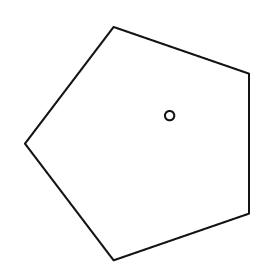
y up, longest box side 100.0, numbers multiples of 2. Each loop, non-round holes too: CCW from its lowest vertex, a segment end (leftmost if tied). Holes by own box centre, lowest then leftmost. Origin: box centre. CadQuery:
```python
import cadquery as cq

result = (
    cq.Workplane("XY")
    .moveTo(-10.0, -50.0)
    .lineTo(48.0, -30.0)
    .lineTo(48.0, 30.0)
    .lineTo(-10.0, 50.0)
    .lineTo(-48.0, 0.0)
    .close()
    .moveTo(14.0, 12.0)
    .circle(2.0)
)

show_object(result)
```